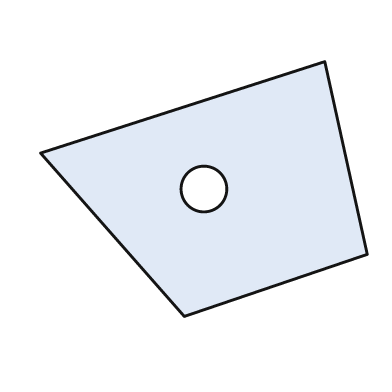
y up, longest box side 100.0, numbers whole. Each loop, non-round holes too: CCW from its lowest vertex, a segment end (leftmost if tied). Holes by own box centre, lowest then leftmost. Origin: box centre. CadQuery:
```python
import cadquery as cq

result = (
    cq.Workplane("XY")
    .moveTo(-6.0, -39.0)
    .lineTo(50.0, -20.0)
    .lineTo(37.0, 39.0)
    .lineTo(-50.0, 11.0)
    .close()
    .moveTo(0.0, 0.0)
    .circle(7.0)
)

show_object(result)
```